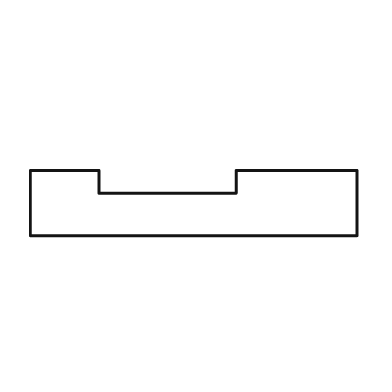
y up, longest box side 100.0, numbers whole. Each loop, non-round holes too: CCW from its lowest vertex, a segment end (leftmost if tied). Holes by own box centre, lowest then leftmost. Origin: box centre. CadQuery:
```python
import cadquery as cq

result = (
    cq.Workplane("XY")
    .moveTo(-50.0, -10.0)
    .lineTo(50.0, -10.0)
    .lineTo(50.0, 10.0)
    .lineTo(13.0, 10.0)
    .lineTo(13.0, 3.0)
    .lineTo(-29.0, 3.0)
    .lineTo(-29.0, 10.0)
    .lineTo(-50.0, 10.0)
    .close()
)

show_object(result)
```